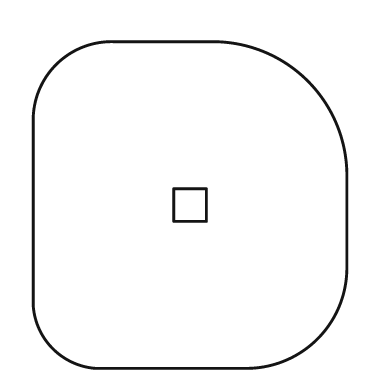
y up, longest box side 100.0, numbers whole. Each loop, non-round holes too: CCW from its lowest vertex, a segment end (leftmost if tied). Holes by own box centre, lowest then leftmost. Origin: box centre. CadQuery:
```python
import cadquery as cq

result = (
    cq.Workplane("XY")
    .moveTo(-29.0, -50.0)
    .lineTo(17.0, -50.0)
    .threePointArc((39.0, -41.0), (48.0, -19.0))
    .lineTo(48.0, 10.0)
    .threePointArc((36.0, 38.0), (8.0, 50.0))
    .lineTo(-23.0, 50.0)
    .threePointArc((-41.0, 43.0), (-48.0, 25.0))
    .lineTo(-48.0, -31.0)
    .threePointArc((-42.0, -44.0), (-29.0, -50.0))
    .close()
    .moveTo(-5.0, -5.0)
    .lineTo(5.0, -5.0)
    .lineTo(5.0, 5.0)
    .lineTo(-5.0, 5.0)
    .close()
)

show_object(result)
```